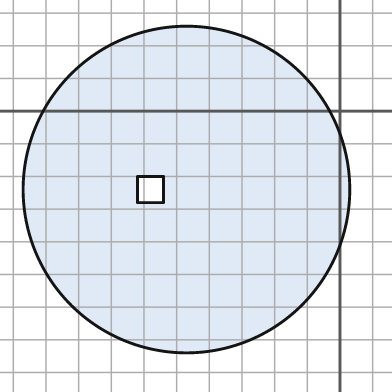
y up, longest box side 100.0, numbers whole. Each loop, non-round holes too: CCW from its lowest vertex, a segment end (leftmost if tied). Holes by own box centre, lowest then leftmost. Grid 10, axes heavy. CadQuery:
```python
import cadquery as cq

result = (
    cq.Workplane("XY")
    .moveTo(-47.0, -24.0)
    .circle(50.0)
    .moveTo(-62.0, -28.0)
    .lineTo(-54.0, -28.0)
    .lineTo(-54.0, -20.0)
    .lineTo(-62.0, -20.0)
    .close()
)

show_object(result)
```